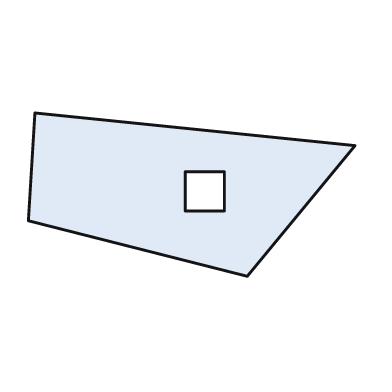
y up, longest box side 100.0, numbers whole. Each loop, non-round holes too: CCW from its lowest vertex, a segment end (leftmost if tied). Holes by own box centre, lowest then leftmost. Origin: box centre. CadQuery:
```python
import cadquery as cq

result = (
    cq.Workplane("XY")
    .moveTo(17.0, -25.0)
    .lineTo(50.0, 15.0)
    .lineTo(-48.0, 25.0)
    .lineTo(-50.0, -8.0)
    .close()
    .moveTo(-2.0, -5.0)
    .lineTo(10.0, -5.0)
    .lineTo(10.0, 7.0)
    .lineTo(-2.0, 7.0)
    .close()
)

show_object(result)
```